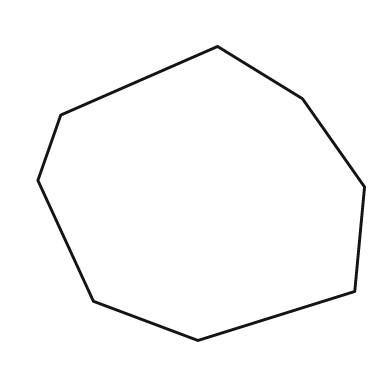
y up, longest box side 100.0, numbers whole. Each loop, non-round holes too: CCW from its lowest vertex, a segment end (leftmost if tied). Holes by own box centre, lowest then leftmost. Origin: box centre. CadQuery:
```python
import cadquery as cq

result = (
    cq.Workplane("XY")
    .moveTo(-1.0, -45.0)
    .lineTo(47.0, -30.0)
    .lineTo(50.0, 2.0)
    .lineTo(31.0, 29.0)
    .lineTo(5.0, 45.0)
    .lineTo(-43.0, 24.0)
    .lineTo(-50.0, 4.0)
    .lineTo(-33.0, -33.0)
    .close()
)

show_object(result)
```